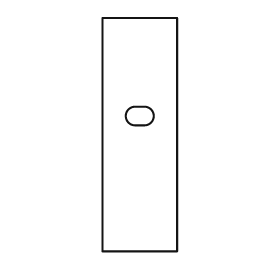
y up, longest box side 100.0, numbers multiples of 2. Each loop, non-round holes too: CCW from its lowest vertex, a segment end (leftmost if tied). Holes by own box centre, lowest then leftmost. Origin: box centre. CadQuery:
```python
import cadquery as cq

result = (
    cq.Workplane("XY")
    .moveTo(-16.0, -50.0)
    .lineTo(16.0, -50.0)
    .lineTo(16.0, 50.0)
    .lineTo(-16.0, 50.0)
    .close()
    .moveTo(-2.0, 4.0)
    .lineTo(2.0, 4.0)
    .threePointArc((6.0, 8.0), (2.0, 12.0))
    .lineTo(-2.0, 12.0)
    .threePointArc((-6.0, 8.0), (-2.0, 4.0))
    .close()
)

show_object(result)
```